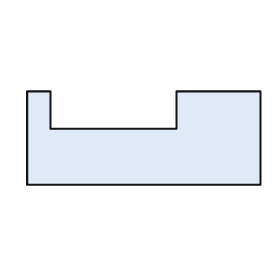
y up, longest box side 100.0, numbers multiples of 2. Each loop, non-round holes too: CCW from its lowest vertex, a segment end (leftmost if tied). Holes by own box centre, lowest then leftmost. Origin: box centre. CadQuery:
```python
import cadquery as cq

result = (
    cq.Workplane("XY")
    .moveTo(-50.0, -20.0)
    .lineTo(50.0, -20.0)
    .lineTo(50.0, 20.0)
    .lineTo(14.0, 20.0)
    .lineTo(14.0, 4.0)
    .lineTo(-40.0, 4.0)
    .lineTo(-40.0, 20.0)
    .lineTo(-50.0, 20.0)
    .close()
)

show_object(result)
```